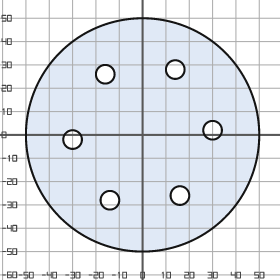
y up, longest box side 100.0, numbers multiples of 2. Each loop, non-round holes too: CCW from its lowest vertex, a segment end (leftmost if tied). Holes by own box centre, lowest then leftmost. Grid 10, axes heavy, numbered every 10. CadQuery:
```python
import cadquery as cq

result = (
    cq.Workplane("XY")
    .moveTo(0.0, 0.0)
    .circle(50.0)
    .moveTo(-14.0, -28.0)
    .circle(4.0)
    .moveTo(16.0, -26.0)
    .circle(4.0)
    .moveTo(-30.0, -2.0)
    .circle(4.0)
    .moveTo(30.0, 2.0)
    .circle(4.0)
    .moveTo(-16.0, 26.0)
    .circle(4.0)
    .moveTo(14.0, 28.0)
    .circle(4.0)
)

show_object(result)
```